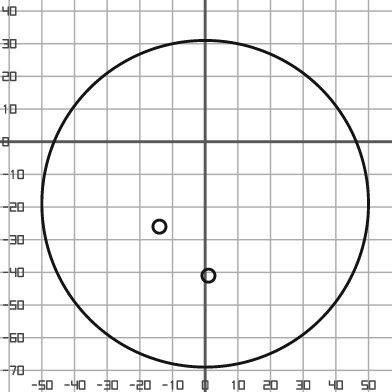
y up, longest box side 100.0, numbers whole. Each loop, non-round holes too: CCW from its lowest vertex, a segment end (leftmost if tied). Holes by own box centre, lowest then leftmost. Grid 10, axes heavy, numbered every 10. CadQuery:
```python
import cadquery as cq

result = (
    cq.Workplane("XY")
    .moveTo(0.0, -19.0)
    .circle(50.0)
    .moveTo(1.0, -41.0)
    .circle(2.0)
    .moveTo(-14.0, -26.0)
    .circle(2.0)
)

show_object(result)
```